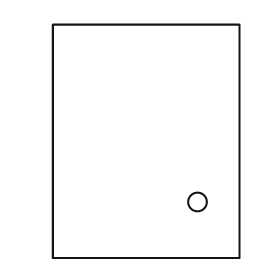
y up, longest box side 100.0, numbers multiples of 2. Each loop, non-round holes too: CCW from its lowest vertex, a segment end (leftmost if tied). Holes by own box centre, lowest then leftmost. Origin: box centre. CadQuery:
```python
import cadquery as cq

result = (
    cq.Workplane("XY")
    .moveTo(-40.0, -50.0)
    .lineTo(40.0, -50.0)
    .lineTo(40.0, 50.0)
    .lineTo(-40.0, 50.0)
    .close()
    .moveTo(22.0, -26.0)
    .circle(4.0)
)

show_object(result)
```